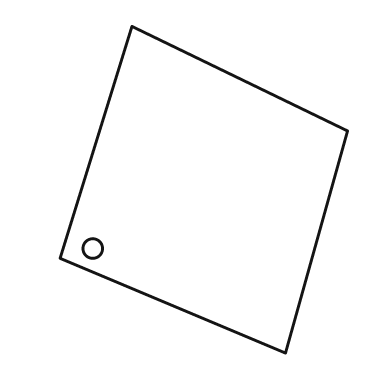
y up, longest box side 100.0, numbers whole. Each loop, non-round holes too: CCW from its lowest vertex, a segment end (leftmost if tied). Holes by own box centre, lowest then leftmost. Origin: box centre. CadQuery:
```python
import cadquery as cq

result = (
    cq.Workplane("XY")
    .moveTo(25.0, -50.0)
    .lineTo(44.0, 18.0)
    .lineTo(-22.0, 50.0)
    .lineTo(-44.0, -21.0)
    .close()
    .moveTo(-34.0, -18.0)
    .circle(3.0)
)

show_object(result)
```